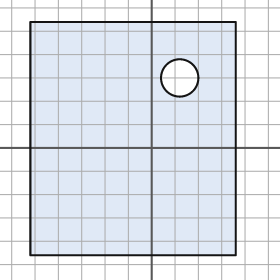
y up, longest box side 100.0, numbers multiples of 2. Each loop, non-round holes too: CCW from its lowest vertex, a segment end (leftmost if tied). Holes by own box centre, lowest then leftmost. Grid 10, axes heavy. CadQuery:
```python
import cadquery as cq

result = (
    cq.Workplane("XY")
    .moveTo(-52.0, -46.0)
    .lineTo(36.0, -46.0)
    .lineTo(36.0, 54.0)
    .lineTo(-52.0, 54.0)
    .close()
    .moveTo(12.0, 30.0)
    .circle(8.0)
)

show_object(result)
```